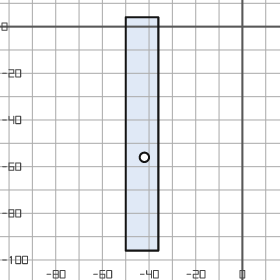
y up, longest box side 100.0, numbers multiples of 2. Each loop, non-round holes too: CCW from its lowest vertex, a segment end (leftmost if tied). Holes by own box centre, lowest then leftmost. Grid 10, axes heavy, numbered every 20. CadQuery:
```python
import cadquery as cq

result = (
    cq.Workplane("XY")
    .moveTo(-50.0, -96.0)
    .lineTo(-36.0, -96.0)
    .lineTo(-36.0, 4.0)
    .lineTo(-50.0, 4.0)
    .close()
    .moveTo(-42.0, -56.0)
    .circle(2.0)
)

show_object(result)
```